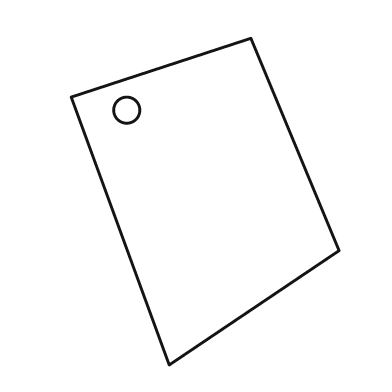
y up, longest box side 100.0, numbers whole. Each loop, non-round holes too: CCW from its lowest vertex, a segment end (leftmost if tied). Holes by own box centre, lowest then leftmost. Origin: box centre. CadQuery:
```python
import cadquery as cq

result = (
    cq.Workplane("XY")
    .moveTo(-11.0, -50.0)
    .lineTo(41.0, -15.0)
    .lineTo(14.0, 50.0)
    .lineTo(-41.0, 32.0)
    .close()
    .moveTo(-24.0, 28.0)
    .circle(4.0)
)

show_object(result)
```